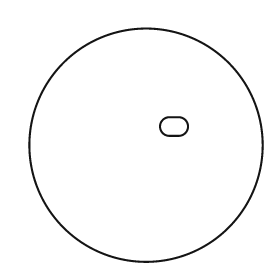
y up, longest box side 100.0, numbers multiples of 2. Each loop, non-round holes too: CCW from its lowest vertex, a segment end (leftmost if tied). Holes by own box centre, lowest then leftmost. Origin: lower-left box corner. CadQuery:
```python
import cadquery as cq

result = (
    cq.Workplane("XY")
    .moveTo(50.0, 50.0)
    .circle(50.0)
    .moveTo(60.0, 54.0)
    .lineTo(64.0, 54.0)
    .threePointArc((68.0, 58.0), (64.0, 62.0))
    .lineTo(60.0, 62.0)
    .threePointArc((56.0, 58.0), (60.0, 54.0))
    .close()
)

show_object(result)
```